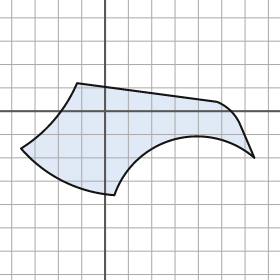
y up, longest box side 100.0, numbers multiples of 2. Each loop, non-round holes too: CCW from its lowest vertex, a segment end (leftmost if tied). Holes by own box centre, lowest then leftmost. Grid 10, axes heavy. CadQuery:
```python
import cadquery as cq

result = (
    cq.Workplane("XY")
    .moveTo(4.0, -36.0)
    .threePointArc((30.0, -12.0), (64.0, -20.0))
    .lineTo(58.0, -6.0)
    .threePointArc((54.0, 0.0), (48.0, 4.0))
    .lineTo(-12.0, 12.0)
    .threePointArc((-22.0, -4.0), (-36.0, -16.0))
    .threePointArc((-18.0, -30.0), (4.0, -36.0))
    .close()
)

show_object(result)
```